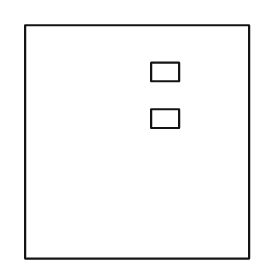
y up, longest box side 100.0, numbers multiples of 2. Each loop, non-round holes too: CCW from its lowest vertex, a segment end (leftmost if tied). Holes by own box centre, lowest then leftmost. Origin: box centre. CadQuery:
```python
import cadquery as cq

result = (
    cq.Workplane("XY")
    .moveTo(-48.0, -50.0)
    .lineTo(48.0, -50.0)
    .lineTo(48.0, 50.0)
    .lineTo(-48.0, 50.0)
    .close()
    .moveTo(6.0, 6.0)
    .lineTo(18.0, 6.0)
    .lineTo(18.0, 14.0)
    .lineTo(6.0, 14.0)
    .close()
    .moveTo(6.0, 26.0)
    .lineTo(18.0, 26.0)
    .lineTo(18.0, 34.0)
    .lineTo(6.0, 34.0)
    .close()
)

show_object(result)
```